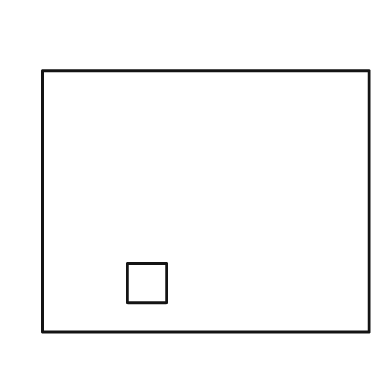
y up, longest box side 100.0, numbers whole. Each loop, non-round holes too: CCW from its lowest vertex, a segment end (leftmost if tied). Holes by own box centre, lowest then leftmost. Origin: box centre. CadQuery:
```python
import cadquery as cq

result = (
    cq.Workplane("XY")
    .moveTo(-50.0, -40.0)
    .lineTo(50.0, -40.0)
    .lineTo(50.0, 40.0)
    .lineTo(-50.0, 40.0)
    .close()
    .moveTo(-24.0, -31.0)
    .lineTo(-12.0, -31.0)
    .lineTo(-12.0, -19.0)
    .lineTo(-24.0, -19.0)
    .close()
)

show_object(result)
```